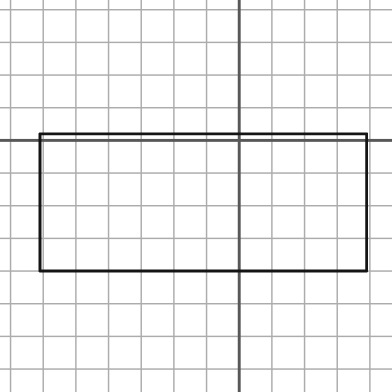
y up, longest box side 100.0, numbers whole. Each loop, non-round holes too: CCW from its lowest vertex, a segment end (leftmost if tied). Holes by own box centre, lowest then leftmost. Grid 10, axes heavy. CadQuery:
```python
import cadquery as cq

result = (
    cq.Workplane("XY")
    .moveTo(-61.0, -40.0)
    .lineTo(39.0, -40.0)
    .lineTo(39.0, 2.0)
    .lineTo(-61.0, 2.0)
    .close()
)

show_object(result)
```